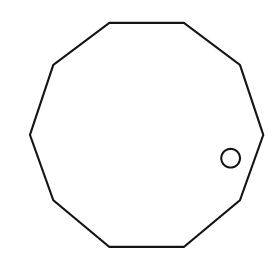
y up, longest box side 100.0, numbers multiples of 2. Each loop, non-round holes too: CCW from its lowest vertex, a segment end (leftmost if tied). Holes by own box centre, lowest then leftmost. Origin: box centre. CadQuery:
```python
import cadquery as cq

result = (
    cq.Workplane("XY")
    .moveTo(-16.0, -48.0)
    .lineTo(16.0, -48.0)
    .lineTo(40.0, -28.0)
    .lineTo(50.0, 0.0)
    .lineTo(40.0, 30.0)
    .lineTo(16.0, 48.0)
    .lineTo(-16.0, 48.0)
    .lineTo(-40.0, 30.0)
    .lineTo(-50.0, 0.0)
    .lineTo(-40.0, -28.0)
    .close()
    .moveTo(36.0, -10.0)
    .circle(4.0)
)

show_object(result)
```